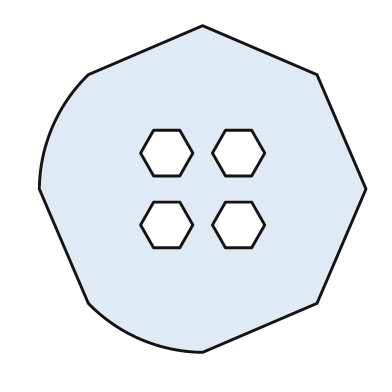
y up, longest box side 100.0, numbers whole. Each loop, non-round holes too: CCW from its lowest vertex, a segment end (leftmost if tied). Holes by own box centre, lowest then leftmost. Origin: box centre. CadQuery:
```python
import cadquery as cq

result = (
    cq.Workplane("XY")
    .moveTo(0.0, -50.0)
    .lineTo(35.0, -35.0)
    .lineTo(50.0, 0.0)
    .lineTo(35.0, 35.0)
    .lineTo(0.0, 50.0)
    .lineTo(-35.0, 35.0)
    .threePointArc((-46.0, 19.0), (-50.0, 0.0))
    .lineTo(-35.0, -35.0)
    .threePointArc((-19.0, -46.0), (0.0, -50.0))
    .close()
    .moveTo(-15.0, -18.0)
    .lineTo(-7.0, -18.0)
    .lineTo(-3.0, -11.0)
    .lineTo(-7.0, -4.0)
    .lineTo(-15.0, -4.0)
    .lineTo(-19.0, -11.0)
    .close()
    .moveTo(7.0, -18.0)
    .lineTo(15.0, -18.0)
    .lineTo(19.0, -11.0)
    .lineTo(15.0, -4.0)
    .lineTo(7.0, -4.0)
    .lineTo(3.0, -11.0)
    .close()
    .moveTo(-15.0, 4.0)
    .lineTo(-7.0, 4.0)
    .lineTo(-3.0, 11.0)
    .lineTo(-7.0, 18.0)
    .lineTo(-15.0, 18.0)
    .lineTo(-19.0, 11.0)
    .close()
    .moveTo(7.0, 4.0)
    .lineTo(15.0, 4.0)
    .lineTo(19.0, 11.0)
    .lineTo(15.0, 18.0)
    .lineTo(7.0, 18.0)
    .lineTo(3.0, 11.0)
    .close()
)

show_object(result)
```